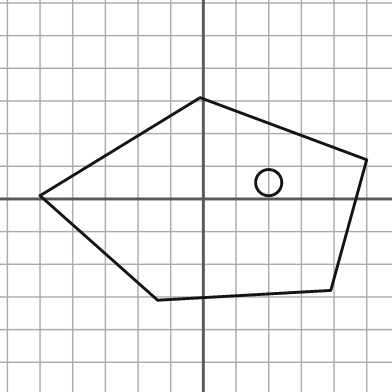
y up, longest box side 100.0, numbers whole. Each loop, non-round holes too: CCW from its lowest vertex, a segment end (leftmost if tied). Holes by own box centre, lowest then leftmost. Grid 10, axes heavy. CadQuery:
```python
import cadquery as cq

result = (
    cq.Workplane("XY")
    .moveTo(-14.0, -31.0)
    .lineTo(39.0, -28.0)
    .lineTo(50.0, 12.0)
    .lineTo(-1.0, 31.0)
    .lineTo(-50.0, 1.0)
    .close()
    .moveTo(20.0, 5.0)
    .circle(4.0)
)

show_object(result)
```